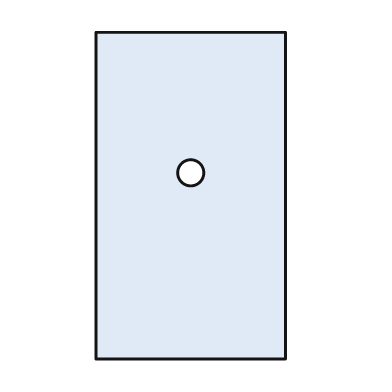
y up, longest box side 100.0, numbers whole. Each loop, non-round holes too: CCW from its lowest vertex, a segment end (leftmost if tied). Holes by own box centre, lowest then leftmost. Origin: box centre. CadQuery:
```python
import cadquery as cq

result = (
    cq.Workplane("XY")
    .moveTo(-29.0, -50.0)
    .lineTo(29.0, -50.0)
    .lineTo(29.0, 50.0)
    .lineTo(-29.0, 50.0)
    .close()
    .moveTo(0.0, 7.0)
    .circle(4.0)
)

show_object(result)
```